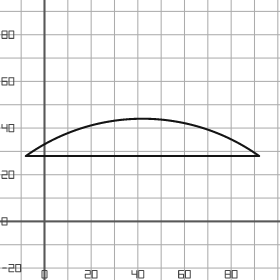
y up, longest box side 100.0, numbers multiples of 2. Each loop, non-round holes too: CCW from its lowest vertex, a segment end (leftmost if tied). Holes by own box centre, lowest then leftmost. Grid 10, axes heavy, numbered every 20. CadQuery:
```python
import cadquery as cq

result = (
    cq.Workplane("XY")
    .moveTo(-8.0, 28.0)
    .lineTo(92.0, 28.0)
    .threePointArc((42.0, 44.0), (-8.0, 28.0))
    .close()
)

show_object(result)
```